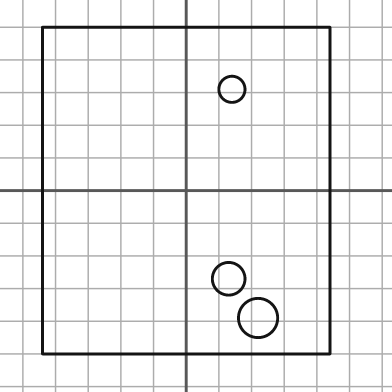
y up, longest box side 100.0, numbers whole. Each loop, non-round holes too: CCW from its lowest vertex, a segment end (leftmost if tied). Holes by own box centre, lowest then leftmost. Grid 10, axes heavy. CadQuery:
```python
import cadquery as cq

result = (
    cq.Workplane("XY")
    .moveTo(-44.0, -50.0)
    .lineTo(44.0, -50.0)
    .lineTo(44.0, 50.0)
    .lineTo(-44.0, 50.0)
    .close()
    .moveTo(22.0, -39.0)
    .circle(6.0)
    .moveTo(13.0, -27.0)
    .circle(5.0)
    .moveTo(14.0, 31.0)
    .circle(4.0)
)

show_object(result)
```